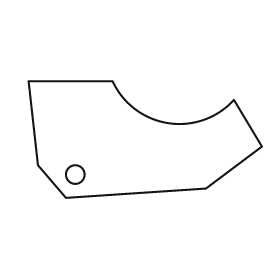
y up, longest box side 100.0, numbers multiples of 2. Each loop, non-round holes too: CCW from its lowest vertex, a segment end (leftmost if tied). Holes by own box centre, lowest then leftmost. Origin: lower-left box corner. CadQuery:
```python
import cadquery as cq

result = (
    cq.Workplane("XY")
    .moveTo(16.0, 0.0)
    .lineTo(76.0, 4.0)
    .lineTo(100.0, 22.0)
    .lineTo(88.0, 42.0)
    .threePointArc((60.0, 32.0), (36.0, 50.0))
    .lineTo(0.0, 50.0)
    .lineTo(4.0, 14.0)
    .close()
    .moveTo(20.0, 10.0)
    .circle(4.0)
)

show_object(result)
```